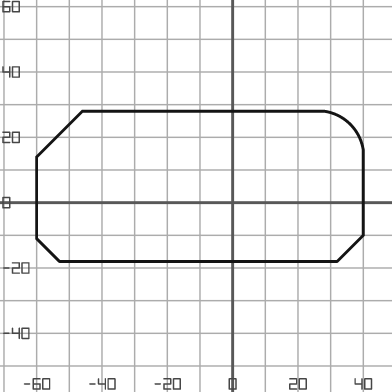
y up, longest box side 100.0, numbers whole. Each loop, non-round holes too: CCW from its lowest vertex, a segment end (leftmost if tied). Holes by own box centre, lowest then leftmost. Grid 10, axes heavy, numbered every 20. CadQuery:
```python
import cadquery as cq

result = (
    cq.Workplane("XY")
    .moveTo(-53.0, -18.0)
    .lineTo(32.0, -18.0)
    .lineTo(40.0, -10.0)
    .lineTo(40.0, 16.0)
    .threePointArc((36.0, 24.0), (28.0, 28.0))
    .lineTo(-46.0, 28.0)
    .lineTo(-60.0, 14.0)
    .lineTo(-60.0, -11.0)
    .close()
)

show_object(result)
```